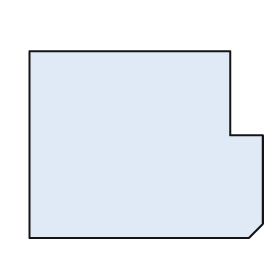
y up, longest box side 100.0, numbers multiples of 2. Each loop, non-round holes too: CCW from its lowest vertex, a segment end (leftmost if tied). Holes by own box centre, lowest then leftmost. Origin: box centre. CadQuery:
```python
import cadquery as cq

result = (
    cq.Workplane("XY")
    .moveTo(-50.0, -40.0)
    .lineTo(44.0, -40.0)
    .lineTo(50.0, -34.0)
    .lineTo(50.0, 4.0)
    .lineTo(36.0, 4.0)
    .lineTo(36.0, 40.0)
    .lineTo(-50.0, 40.0)
    .close()
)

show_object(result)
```